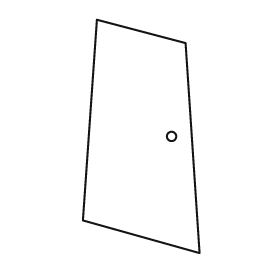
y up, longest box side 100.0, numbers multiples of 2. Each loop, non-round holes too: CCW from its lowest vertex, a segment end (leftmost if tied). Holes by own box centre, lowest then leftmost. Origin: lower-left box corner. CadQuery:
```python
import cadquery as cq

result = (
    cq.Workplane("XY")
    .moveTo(50.0, 0.0)
    .lineTo(44.0, 90.0)
    .lineTo(6.0, 100.0)
    .lineTo(0.0, 14.0)
    .close()
    .moveTo(38.0, 50.0)
    .circle(2.0)
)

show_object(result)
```